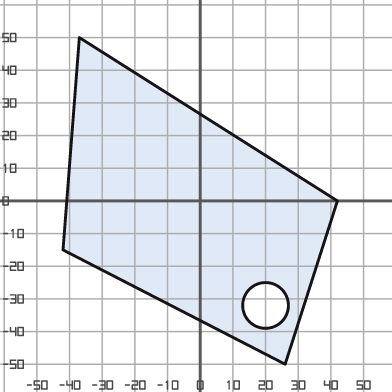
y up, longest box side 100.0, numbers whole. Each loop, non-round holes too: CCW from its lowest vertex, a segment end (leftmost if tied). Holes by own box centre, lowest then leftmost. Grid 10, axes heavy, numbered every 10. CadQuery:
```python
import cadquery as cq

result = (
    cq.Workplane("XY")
    .moveTo(26.0, -50.0)
    .lineTo(42.0, 0.0)
    .lineTo(-37.0, 50.0)
    .lineTo(-42.0, -15.0)
    .close()
    .moveTo(20.0, -32.0)
    .circle(7.0)
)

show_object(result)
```